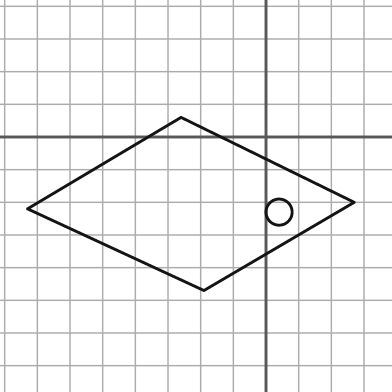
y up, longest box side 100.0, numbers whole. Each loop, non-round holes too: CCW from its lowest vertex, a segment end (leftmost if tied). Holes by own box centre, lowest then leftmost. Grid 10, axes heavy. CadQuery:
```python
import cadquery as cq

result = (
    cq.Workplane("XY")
    .moveTo(-19.0, -47.0)
    .lineTo(27.0, -20.0)
    .lineTo(-26.0, 6.0)
    .lineTo(-73.0, -22.0)
    .close()
    .moveTo(4.0, -23.0)
    .circle(4.0)
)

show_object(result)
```